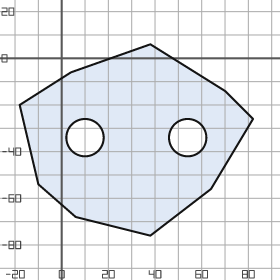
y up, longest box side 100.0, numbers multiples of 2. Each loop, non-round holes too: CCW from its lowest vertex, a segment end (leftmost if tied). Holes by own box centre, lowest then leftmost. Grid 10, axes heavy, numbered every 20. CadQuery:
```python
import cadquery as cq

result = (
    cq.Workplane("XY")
    .moveTo(38.0, -76.0)
    .lineTo(64.0, -56.0)
    .lineTo(82.0, -26.0)
    .lineTo(70.0, -14.0)
    .lineTo(38.0, 6.0)
    .lineTo(4.0, -6.0)
    .lineTo(-18.0, -20.0)
    .lineTo(-10.0, -54.0)
    .lineTo(6.0, -68.0)
    .close()
    .moveTo(10.0, -34.0)
    .circle(8.0)
    .moveTo(54.0, -34.0)
    .circle(8.0)
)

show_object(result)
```